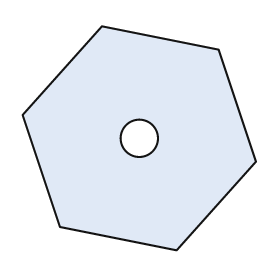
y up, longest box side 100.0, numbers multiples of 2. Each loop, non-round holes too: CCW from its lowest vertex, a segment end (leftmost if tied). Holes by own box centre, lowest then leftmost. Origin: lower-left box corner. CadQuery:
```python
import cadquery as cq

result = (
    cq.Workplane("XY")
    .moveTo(66.0, 0.0)
    .lineTo(100.0, 38.0)
    .lineTo(84.0, 86.0)
    .lineTo(34.0, 96.0)
    .lineTo(0.0, 58.0)
    .lineTo(16.0, 10.0)
    .close()
    .moveTo(50.0, 48.0)
    .circle(8.0)
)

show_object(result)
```